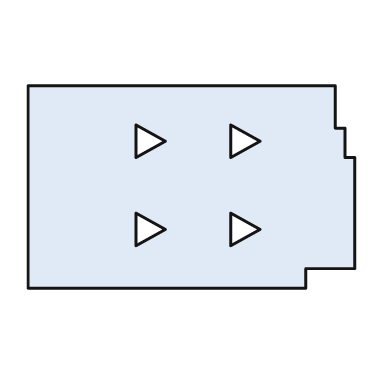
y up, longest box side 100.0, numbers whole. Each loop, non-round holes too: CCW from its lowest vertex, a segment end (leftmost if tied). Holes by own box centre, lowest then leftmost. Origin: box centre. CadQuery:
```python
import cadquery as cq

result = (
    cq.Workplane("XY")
    .moveTo(-50.0, -31.0)
    .lineTo(35.0, -31.0)
    .lineTo(35.0, -25.0)
    .lineTo(50.0, -25.0)
    .lineTo(50.0, 9.0)
    .lineTo(47.0, 9.0)
    .lineTo(47.0, 18.0)
    .lineTo(44.0, 18.0)
    .lineTo(44.0, 31.0)
    .lineTo(-50.0, 31.0)
    .close()
    .moveTo(-17.0, -18.0)
    .lineTo(-8.0, -13.0)
    .lineTo(-17.0, -8.0)
    .close()
    .moveTo(12.0, -18.0)
    .lineTo(21.0, -13.0)
    .lineTo(12.0, -8.0)
    .close()
    .moveTo(-17.0, 9.0)
    .lineTo(-8.0, 14.0)
    .lineTo(-17.0, 19.0)
    .close()
    .moveTo(12.0, 9.0)
    .lineTo(21.0, 14.0)
    .lineTo(12.0, 19.0)
    .close()
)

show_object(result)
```